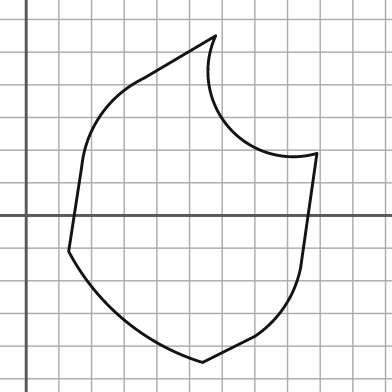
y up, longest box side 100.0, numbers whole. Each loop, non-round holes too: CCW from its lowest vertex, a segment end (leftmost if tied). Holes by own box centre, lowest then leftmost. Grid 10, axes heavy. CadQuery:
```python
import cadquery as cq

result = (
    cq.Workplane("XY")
    .moveTo(54.0, -45.0)
    .lineTo(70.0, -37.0)
    .threePointArc((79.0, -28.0), (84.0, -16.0))
    .lineTo(89.0, 19.0)
    .threePointArc((62.0, 27.0), (58.0, 55.0))
    .lineTo(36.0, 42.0)
    .threePointArc((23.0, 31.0), (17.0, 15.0))
    .lineTo(13.0, -11.0)
    .threePointArc((30.0, -32.0), (54.0, -45.0))
    .close()
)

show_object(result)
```